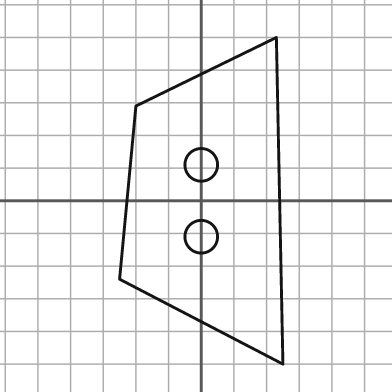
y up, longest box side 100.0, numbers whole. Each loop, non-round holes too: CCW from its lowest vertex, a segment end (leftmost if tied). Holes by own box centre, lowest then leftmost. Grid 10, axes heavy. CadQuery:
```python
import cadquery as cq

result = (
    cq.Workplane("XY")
    .moveTo(25.0, -50.0)
    .lineTo(23.0, 50.0)
    .lineTo(-20.0, 29.0)
    .lineTo(-25.0, -24.0)
    .close()
    .moveTo(0.0, -11.0)
    .circle(5.0)
    .moveTo(0.0, 11.0)
    .circle(5.0)
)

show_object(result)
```